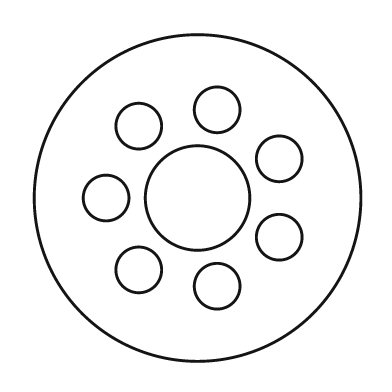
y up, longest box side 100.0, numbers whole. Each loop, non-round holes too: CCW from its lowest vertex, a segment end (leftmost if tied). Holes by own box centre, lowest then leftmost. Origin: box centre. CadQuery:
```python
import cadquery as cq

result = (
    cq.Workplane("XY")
    .moveTo(0.0, 0.0)
    .circle(50.0)
    .moveTo(6.0, -27.0)
    .circle(7.0)
    .moveTo(-18.0, -22.0)
    .circle(7.0)
    .moveTo(25.0, -12.0)
    .circle(7.0)
    .moveTo(-28.0, 0.0)
    .circle(7.0)
    .moveTo(0.0, 0.0)
    .circle(16.0)
    .moveTo(25.0, 12.0)
    .circle(7.0)
    .moveTo(-18.0, 22.0)
    .circle(7.0)
    .moveTo(6.0, 27.0)
    .circle(7.0)
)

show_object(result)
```